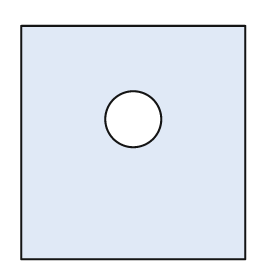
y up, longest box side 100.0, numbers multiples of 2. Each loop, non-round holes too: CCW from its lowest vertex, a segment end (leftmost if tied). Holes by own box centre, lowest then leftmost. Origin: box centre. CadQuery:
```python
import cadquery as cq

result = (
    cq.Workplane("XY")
    .moveTo(-48.0, -50.0)
    .lineTo(48.0, -50.0)
    .lineTo(48.0, 50.0)
    .lineTo(-48.0, 50.0)
    .close()
    .moveTo(0.0, 10.0)
    .circle(12.0)
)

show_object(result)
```